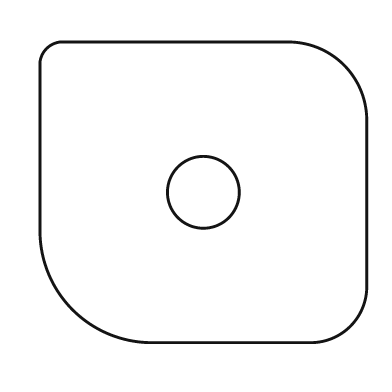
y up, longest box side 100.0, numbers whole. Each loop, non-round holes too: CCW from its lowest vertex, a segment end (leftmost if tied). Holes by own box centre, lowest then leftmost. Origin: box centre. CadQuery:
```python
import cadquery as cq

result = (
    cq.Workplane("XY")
    .moveTo(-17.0, -46.0)
    .lineTo(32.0, -46.0)
    .threePointArc((45.0, -41.0), (50.0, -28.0))
    .lineTo(50.0, 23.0)
    .threePointArc((43.0, 39.0), (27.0, 46.0))
    .lineTo(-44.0, 46.0)
    .threePointArc((-48.0, 44.0), (-50.0, 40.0))
    .lineTo(-50.0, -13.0)
    .threePointArc((-40.0, -36.0), (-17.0, -46.0))
    .close()
    .moveTo(0.0, 0.0)
    .circle(11.0)
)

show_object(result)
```